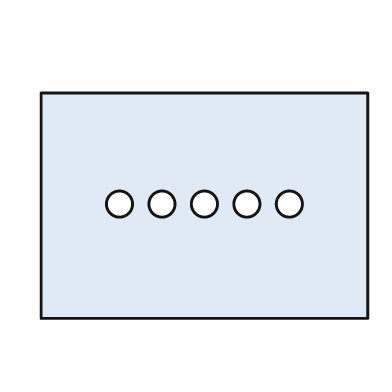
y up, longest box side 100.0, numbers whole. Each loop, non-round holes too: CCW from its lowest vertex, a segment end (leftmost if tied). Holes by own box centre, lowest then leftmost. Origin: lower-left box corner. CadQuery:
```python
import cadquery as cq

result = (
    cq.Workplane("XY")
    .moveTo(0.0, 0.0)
    .lineTo(100.0, 0.0)
    .lineTo(100.0, 69.0)
    .lineTo(0.0, 69.0)
    .close()
    .moveTo(24.0, 35.0)
    .circle(4.0)
    .moveTo(37.0, 35.0)
    .circle(4.0)
    .moveTo(50.0, 35.0)
    .circle(4.0)
    .moveTo(63.0, 35.0)
    .circle(4.0)
    .moveTo(76.0, 35.0)
    .circle(4.0)
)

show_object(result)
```